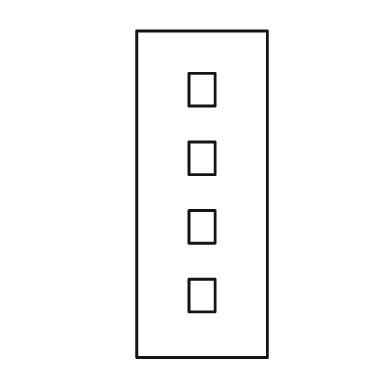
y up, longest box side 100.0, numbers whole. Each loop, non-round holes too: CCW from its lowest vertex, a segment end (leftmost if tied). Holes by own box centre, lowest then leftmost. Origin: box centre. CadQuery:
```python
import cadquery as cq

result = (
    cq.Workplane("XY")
    .moveTo(-20.0, -50.0)
    .lineTo(20.0, -50.0)
    .lineTo(20.0, 50.0)
    .lineTo(-20.0, 50.0)
    .close()
    .moveTo(-4.0, -36.0)
    .lineTo(4.0, -36.0)
    .lineTo(4.0, -26.0)
    .lineTo(-4.0, -26.0)
    .close()
    .moveTo(-4.0, -15.0)
    .lineTo(4.0, -15.0)
    .lineTo(4.0, -5.0)
    .lineTo(-4.0, -5.0)
    .close()
    .moveTo(-4.0, 6.0)
    .lineTo(4.0, 6.0)
    .lineTo(4.0, 16.0)
    .lineTo(-4.0, 16.0)
    .close()
    .moveTo(-4.0, 27.0)
    .lineTo(4.0, 27.0)
    .lineTo(4.0, 37.0)
    .lineTo(-4.0, 37.0)
    .close()
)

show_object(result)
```